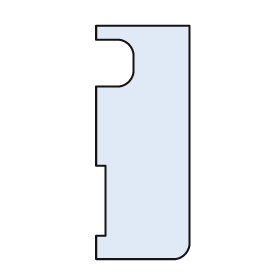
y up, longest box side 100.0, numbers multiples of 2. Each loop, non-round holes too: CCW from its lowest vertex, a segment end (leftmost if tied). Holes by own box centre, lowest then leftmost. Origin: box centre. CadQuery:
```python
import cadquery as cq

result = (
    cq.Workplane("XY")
    .moveTo(-20.0, -50.0)
    .lineTo(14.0, -50.0)
    .threePointArc((18.0, -48.0), (20.0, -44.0))
    .lineTo(20.0, 50.0)
    .lineTo(-20.0, 50.0)
    .lineTo(-20.0, 44.0)
    .lineTo(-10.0, 44.0)
    .threePointArc((-6.0, 42.0), (-4.0, 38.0))
    .lineTo(-4.0, 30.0)
    .threePointArc((-6.0, 26.0), (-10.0, 24.0))
    .lineTo(-20.0, 24.0)
    .lineTo(-20.0, -10.0)
    .lineTo(-16.0, -10.0)
    .lineTo(-16.0, -40.0)
    .lineTo(-20.0, -40.0)
    .close()
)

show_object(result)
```